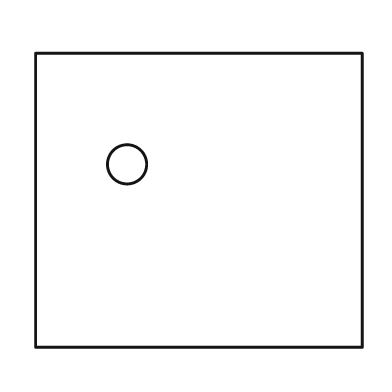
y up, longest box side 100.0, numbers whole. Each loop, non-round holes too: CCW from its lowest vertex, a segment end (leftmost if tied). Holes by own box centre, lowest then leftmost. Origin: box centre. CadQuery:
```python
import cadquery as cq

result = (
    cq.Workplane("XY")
    .moveTo(-50.0, -45.0)
    .lineTo(50.0, -45.0)
    .lineTo(50.0, 45.0)
    .lineTo(-50.0, 45.0)
    .close()
    .moveTo(-22.0, 11.0)
    .circle(6.0)
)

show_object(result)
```